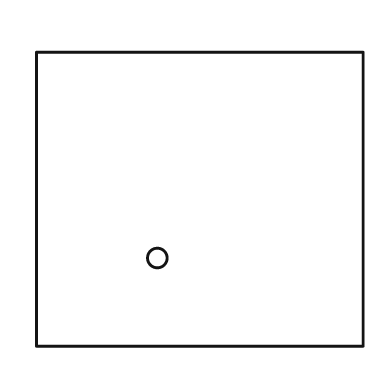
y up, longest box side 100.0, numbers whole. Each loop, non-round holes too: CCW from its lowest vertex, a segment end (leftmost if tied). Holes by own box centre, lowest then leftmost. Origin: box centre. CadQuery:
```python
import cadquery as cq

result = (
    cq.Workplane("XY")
    .moveTo(-50.0, -45.0)
    .lineTo(50.0, -45.0)
    .lineTo(50.0, 45.0)
    .lineTo(-50.0, 45.0)
    .close()
    .moveTo(-13.0, -18.0)
    .circle(3.0)
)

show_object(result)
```